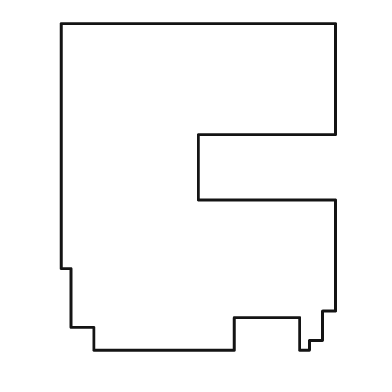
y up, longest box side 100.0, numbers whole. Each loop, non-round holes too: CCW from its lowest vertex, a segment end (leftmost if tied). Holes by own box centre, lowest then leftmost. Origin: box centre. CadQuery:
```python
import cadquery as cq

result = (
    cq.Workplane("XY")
    .moveTo(-32.0, -50.0)
    .lineTo(11.0, -50.0)
    .lineTo(11.0, -40.0)
    .lineTo(31.0, -40.0)
    .lineTo(31.0, -50.0)
    .lineTo(34.0, -50.0)
    .lineTo(34.0, -47.0)
    .lineTo(38.0, -47.0)
    .lineTo(38.0, -38.0)
    .lineTo(42.0, -38.0)
    .lineTo(42.0, -4.0)
    .lineTo(0.0, -4.0)
    .lineTo(0.0, 16.0)
    .lineTo(42.0, 16.0)
    .lineTo(42.0, 50.0)
    .lineTo(-42.0, 50.0)
    .lineTo(-42.0, -25.0)
    .lineTo(-39.0, -25.0)
    .lineTo(-39.0, -43.0)
    .lineTo(-32.0, -43.0)
    .close()
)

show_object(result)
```